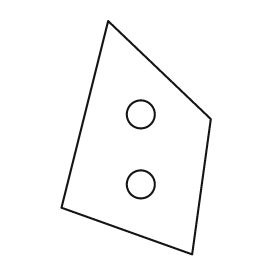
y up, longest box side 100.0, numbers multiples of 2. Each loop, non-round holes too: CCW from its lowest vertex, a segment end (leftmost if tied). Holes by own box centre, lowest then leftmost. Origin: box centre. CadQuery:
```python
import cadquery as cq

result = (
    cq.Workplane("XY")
    .moveTo(24.0, -50.0)
    .lineTo(32.0, 8.0)
    .lineTo(-12.0, 50.0)
    .lineTo(-32.0, -30.0)
    .close()
    .moveTo(2.0, -20.0)
    .circle(6.0)
    .moveTo(2.0, 10.0)
    .circle(6.0)
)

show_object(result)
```